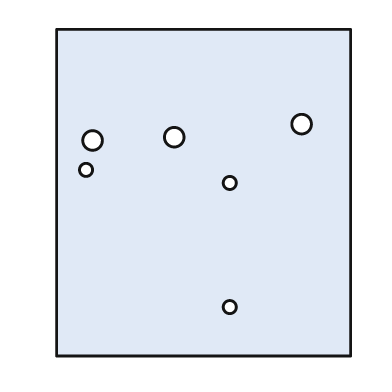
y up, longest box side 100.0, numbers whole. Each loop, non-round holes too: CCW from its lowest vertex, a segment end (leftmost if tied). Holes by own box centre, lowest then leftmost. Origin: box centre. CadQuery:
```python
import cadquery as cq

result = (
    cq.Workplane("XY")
    .moveTo(-45.0, -50.0)
    .lineTo(45.0, -50.0)
    .lineTo(45.0, 50.0)
    .lineTo(-45.0, 50.0)
    .close()
    .moveTo(8.0, -35.0)
    .circle(2.0)
    .moveTo(8.0, 3.0)
    .circle(2.0)
    .moveTo(-36.0, 7.0)
    .circle(2.0)
    .moveTo(-34.0, 16.0)
    .circle(3.0)
    .moveTo(-9.0, 17.0)
    .circle(3.0)
    .moveTo(30.0, 21.0)
    .circle(3.0)
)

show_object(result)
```